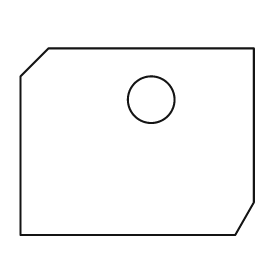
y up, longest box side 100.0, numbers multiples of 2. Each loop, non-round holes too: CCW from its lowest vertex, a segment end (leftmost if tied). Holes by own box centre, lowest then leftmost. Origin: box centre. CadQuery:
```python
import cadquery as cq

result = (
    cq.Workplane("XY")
    .moveTo(-50.0, -40.0)
    .lineTo(42.0, -40.0)
    .lineTo(50.0, -26.0)
    .lineTo(50.0, 40.0)
    .lineTo(-38.0, 40.0)
    .lineTo(-50.0, 28.0)
    .close()
    .moveTo(6.0, 18.0)
    .circle(10.0)
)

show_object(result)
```